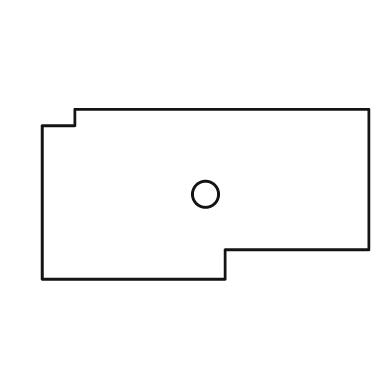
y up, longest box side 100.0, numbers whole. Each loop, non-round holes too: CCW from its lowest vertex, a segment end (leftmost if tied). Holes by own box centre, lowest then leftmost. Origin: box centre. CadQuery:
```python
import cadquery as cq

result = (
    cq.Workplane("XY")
    .moveTo(-50.0, -26.0)
    .lineTo(6.0, -26.0)
    .lineTo(6.0, -17.0)
    .lineTo(50.0, -17.0)
    .lineTo(50.0, 26.0)
    .lineTo(-40.0, 26.0)
    .lineTo(-40.0, 21.0)
    .lineTo(-50.0, 21.0)
    .close()
    .moveTo(0.0, 0.0)
    .circle(4.0)
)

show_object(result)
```